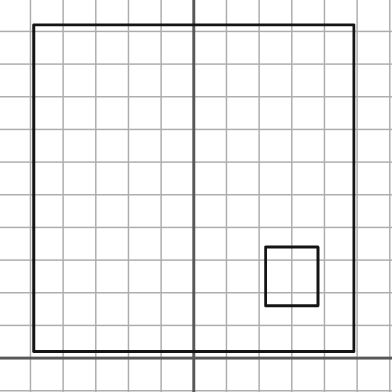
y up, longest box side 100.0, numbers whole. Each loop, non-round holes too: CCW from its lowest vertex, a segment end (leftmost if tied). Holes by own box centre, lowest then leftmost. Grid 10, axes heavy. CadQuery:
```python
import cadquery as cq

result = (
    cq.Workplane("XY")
    .moveTo(-49.0, 2.0)
    .lineTo(49.0, 2.0)
    .lineTo(49.0, 102.0)
    .lineTo(-49.0, 102.0)
    .close()
    .moveTo(22.0, 16.0)
    .lineTo(38.0, 16.0)
    .lineTo(38.0, 34.0)
    .lineTo(22.0, 34.0)
    .close()
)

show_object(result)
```